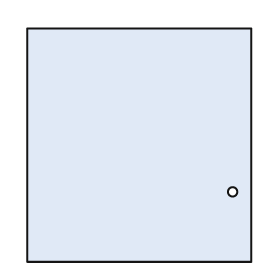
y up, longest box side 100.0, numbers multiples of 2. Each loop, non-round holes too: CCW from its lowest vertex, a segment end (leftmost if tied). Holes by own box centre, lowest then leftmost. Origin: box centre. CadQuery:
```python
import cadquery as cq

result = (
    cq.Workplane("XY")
    .moveTo(-48.0, -50.0)
    .lineTo(48.0, -50.0)
    .lineTo(48.0, 50.0)
    .lineTo(-48.0, 50.0)
    .close()
    .moveTo(40.0, -20.0)
    .circle(2.0)
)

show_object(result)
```